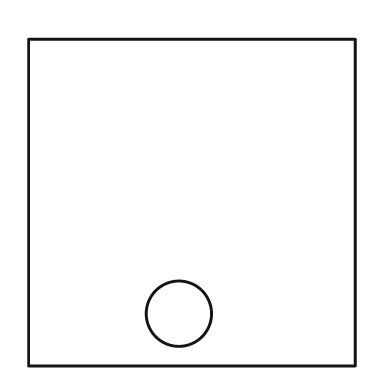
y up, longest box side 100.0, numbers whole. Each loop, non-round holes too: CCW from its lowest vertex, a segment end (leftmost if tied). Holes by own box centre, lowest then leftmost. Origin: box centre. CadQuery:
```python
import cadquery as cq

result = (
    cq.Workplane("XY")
    .moveTo(-50.0, -50.0)
    .lineTo(50.0, -50.0)
    .lineTo(50.0, 50.0)
    .lineTo(-50.0, 50.0)
    .close()
    .moveTo(-4.0, -34.0)
    .circle(10.0)
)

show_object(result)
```